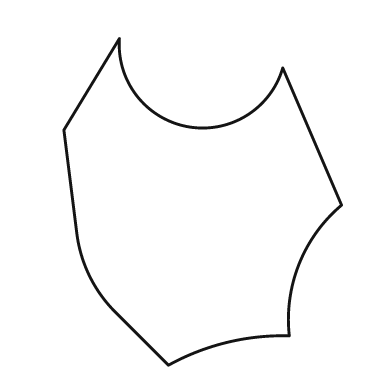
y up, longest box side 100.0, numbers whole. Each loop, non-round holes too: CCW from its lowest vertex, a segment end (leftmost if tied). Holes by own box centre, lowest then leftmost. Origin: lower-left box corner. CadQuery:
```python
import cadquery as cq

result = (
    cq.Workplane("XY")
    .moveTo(32.0, 0.0)
    .threePointArc((50.0, 7.0), (69.0, 9.0))
    .threePointArc((72.0, 31.0), (85.0, 49.0))
    .lineTo(67.0, 91.0)
    .threePointArc((38.0, 73.0), (17.0, 100.0))
    .lineTo(0.0, 72.0)
    .lineTo(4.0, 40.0)
    .threePointArc((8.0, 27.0), (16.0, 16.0))
    .close()
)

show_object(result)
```